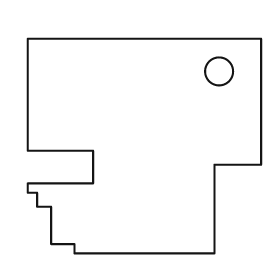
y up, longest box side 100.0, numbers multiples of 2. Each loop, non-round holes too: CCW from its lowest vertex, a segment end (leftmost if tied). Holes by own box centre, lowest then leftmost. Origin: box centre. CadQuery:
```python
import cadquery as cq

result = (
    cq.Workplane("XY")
    .moveTo(-30.0, -46.0)
    .lineTo(30.0, -46.0)
    .lineTo(30.0, -8.0)
    .lineTo(50.0, -8.0)
    .lineTo(50.0, 46.0)
    .lineTo(-50.0, 46.0)
    .lineTo(-50.0, -2.0)
    .lineTo(-22.0, -2.0)
    .lineTo(-22.0, -16.0)
    .lineTo(-50.0, -16.0)
    .lineTo(-50.0, -20.0)
    .lineTo(-46.0, -20.0)
    .lineTo(-46.0, -26.0)
    .lineTo(-40.0, -26.0)
    .lineTo(-40.0, -42.0)
    .lineTo(-30.0, -42.0)
    .close()
    .moveTo(32.0, 32.0)
    .circle(6.0)
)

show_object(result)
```